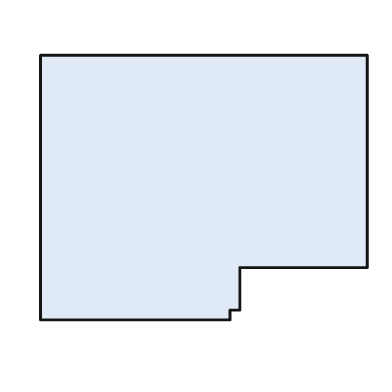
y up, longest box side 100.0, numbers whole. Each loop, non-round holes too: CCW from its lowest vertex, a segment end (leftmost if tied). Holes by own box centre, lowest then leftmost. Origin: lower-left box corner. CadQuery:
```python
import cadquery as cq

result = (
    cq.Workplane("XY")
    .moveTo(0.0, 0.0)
    .lineTo(58.0, 0.0)
    .lineTo(58.0, 3.0)
    .lineTo(61.0, 3.0)
    .lineTo(61.0, 16.0)
    .lineTo(100.0, 16.0)
    .lineTo(100.0, 81.0)
    .lineTo(0.0, 81.0)
    .close()
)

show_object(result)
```